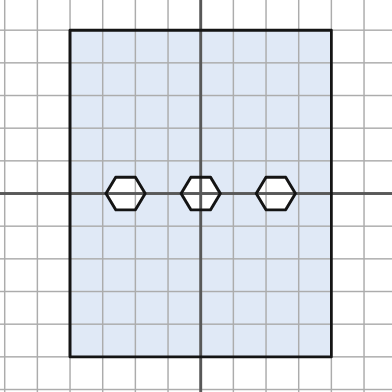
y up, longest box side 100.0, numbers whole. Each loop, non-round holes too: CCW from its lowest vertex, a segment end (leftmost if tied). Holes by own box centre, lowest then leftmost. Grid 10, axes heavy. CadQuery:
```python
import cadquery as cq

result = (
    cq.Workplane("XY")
    .moveTo(-40.0, -50.0)
    .lineTo(40.0, -50.0)
    .lineTo(40.0, 50.0)
    .lineTo(-40.0, 50.0)
    .close()
    .moveTo(-26.0, -5.0)
    .lineTo(-20.0, -5.0)
    .lineTo(-17.0, 0.0)
    .lineTo(-20.0, 5.0)
    .lineTo(-26.0, 5.0)
    .lineTo(-29.0, 0.0)
    .close()
    .moveTo(-3.0, -5.0)
    .lineTo(3.0, -5.0)
    .lineTo(6.0, 0.0)
    .lineTo(3.0, 5.0)
    .lineTo(-3.0, 5.0)
    .lineTo(-6.0, 0.0)
    .close()
    .moveTo(20.0, -5.0)
    .lineTo(26.0, -5.0)
    .lineTo(29.0, 0.0)
    .lineTo(26.0, 5.0)
    .lineTo(20.0, 5.0)
    .lineTo(17.0, 0.0)
    .close()
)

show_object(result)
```